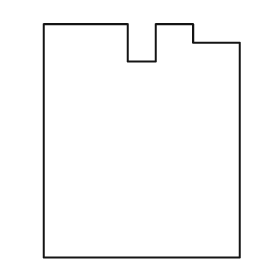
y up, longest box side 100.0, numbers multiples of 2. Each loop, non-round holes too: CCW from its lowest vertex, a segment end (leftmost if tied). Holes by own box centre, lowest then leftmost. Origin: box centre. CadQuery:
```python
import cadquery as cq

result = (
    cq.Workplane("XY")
    .moveTo(-42.0, -50.0)
    .lineTo(42.0, -50.0)
    .lineTo(42.0, 42.0)
    .lineTo(22.0, 42.0)
    .lineTo(22.0, 50.0)
    .lineTo(6.0, 50.0)
    .lineTo(6.0, 34.0)
    .lineTo(-6.0, 34.0)
    .lineTo(-6.0, 50.0)
    .lineTo(-42.0, 50.0)
    .close()
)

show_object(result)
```